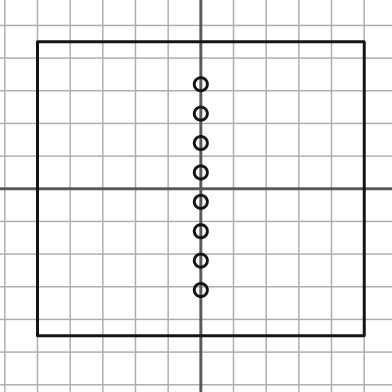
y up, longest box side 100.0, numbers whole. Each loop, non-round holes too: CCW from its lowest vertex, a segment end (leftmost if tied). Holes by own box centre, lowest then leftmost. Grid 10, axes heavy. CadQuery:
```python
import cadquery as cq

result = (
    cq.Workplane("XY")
    .moveTo(-50.0, -45.0)
    .lineTo(50.0, -45.0)
    .lineTo(50.0, 45.0)
    .lineTo(-50.0, 45.0)
    .close()
    .moveTo(0.0, -31.0)
    .circle(2.0)
    .moveTo(0.0, -22.0)
    .circle(2.0)
    .moveTo(0.0, -13.0)
    .circle(2.0)
    .moveTo(0.0, -4.0)
    .circle(2.0)
    .moveTo(0.0, 5.0)
    .circle(2.0)
    .moveTo(0.0, 14.0)
    .circle(2.0)
    .moveTo(0.0, 23.0)
    .circle(2.0)
    .moveTo(0.0, 32.0)
    .circle(2.0)
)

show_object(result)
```